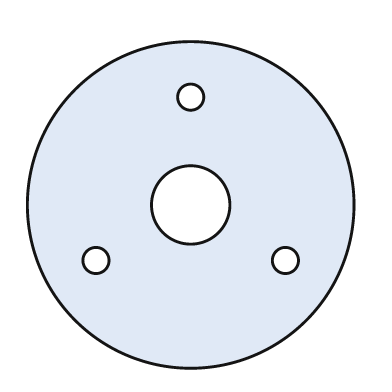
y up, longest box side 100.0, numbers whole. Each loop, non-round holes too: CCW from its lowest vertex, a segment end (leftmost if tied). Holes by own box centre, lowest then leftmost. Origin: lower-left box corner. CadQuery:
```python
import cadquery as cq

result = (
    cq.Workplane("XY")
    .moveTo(50.0, 50.0)
    .circle(50.0)
    .moveTo(21.0, 33.0)
    .circle(4.0)
    .moveTo(79.0, 33.0)
    .circle(4.0)
    .moveTo(50.0, 50.0)
    .circle(12.0)
    .moveTo(50.0, 83.0)
    .circle(4.0)
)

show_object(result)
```